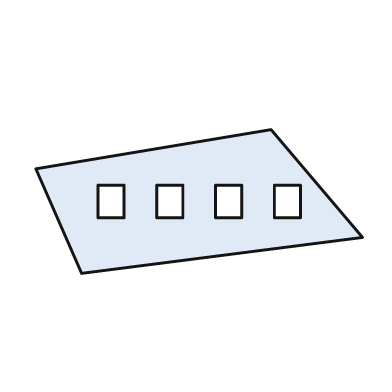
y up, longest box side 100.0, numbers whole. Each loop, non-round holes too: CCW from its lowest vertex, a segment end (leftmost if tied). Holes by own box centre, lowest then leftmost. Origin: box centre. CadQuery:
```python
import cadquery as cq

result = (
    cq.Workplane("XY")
    .moveTo(-36.0, -22.0)
    .lineTo(50.0, -11.0)
    .lineTo(22.0, 22.0)
    .lineTo(-50.0, 10.0)
    .close()
    .moveTo(-31.0, -5.0)
    .lineTo(-23.0, -5.0)
    .lineTo(-23.0, 5.0)
    .lineTo(-31.0, 5.0)
    .close()
    .moveTo(-13.0, -5.0)
    .lineTo(-5.0, -5.0)
    .lineTo(-5.0, 5.0)
    .lineTo(-13.0, 5.0)
    .close()
    .moveTo(5.0, -5.0)
    .lineTo(13.0, -5.0)
    .lineTo(13.0, 5.0)
    .lineTo(5.0, 5.0)
    .close()
    .moveTo(23.0, -5.0)
    .lineTo(31.0, -5.0)
    .lineTo(31.0, 5.0)
    .lineTo(23.0, 5.0)
    .close()
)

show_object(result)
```